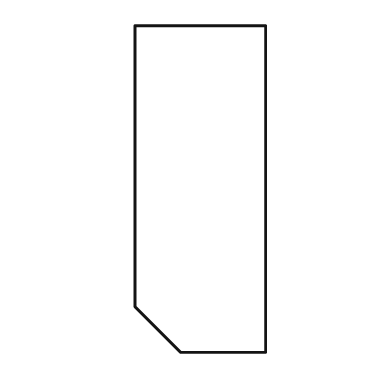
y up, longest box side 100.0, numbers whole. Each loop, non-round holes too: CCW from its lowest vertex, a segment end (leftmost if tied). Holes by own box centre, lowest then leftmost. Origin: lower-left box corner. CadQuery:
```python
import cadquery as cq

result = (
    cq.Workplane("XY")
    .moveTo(14.0, 0.0)
    .lineTo(40.0, 0.0)
    .lineTo(40.0, 100.0)
    .lineTo(0.0, 100.0)
    .lineTo(0.0, 14.0)
    .close()
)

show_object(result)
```